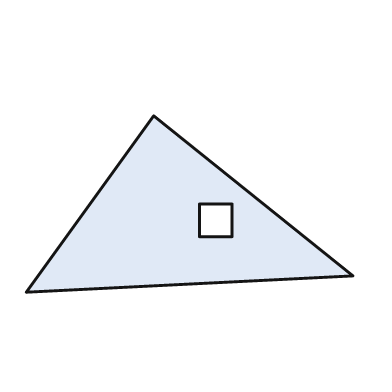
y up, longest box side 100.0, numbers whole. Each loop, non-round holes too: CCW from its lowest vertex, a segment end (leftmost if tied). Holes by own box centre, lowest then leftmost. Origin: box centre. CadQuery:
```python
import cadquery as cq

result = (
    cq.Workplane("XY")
    .moveTo(-50.0, -27.0)
    .lineTo(50.0, -22.0)
    .lineTo(-11.0, 27.0)
    .close()
    .moveTo(3.0, -10.0)
    .lineTo(13.0, -10.0)
    .lineTo(13.0, 0.0)
    .lineTo(3.0, 0.0)
    .close()
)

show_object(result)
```